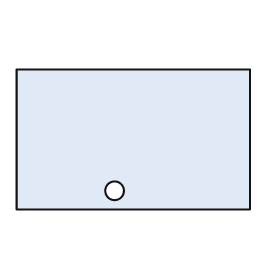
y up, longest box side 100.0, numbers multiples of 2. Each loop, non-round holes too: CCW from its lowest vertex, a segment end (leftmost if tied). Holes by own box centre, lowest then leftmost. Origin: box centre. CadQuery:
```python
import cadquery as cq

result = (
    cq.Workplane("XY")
    .moveTo(-50.0, -30.0)
    .lineTo(50.0, -30.0)
    .lineTo(50.0, 30.0)
    .lineTo(-50.0, 30.0)
    .close()
    .moveTo(-8.0, -22.0)
    .circle(4.0)
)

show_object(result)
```